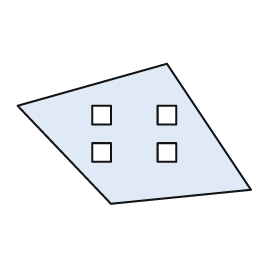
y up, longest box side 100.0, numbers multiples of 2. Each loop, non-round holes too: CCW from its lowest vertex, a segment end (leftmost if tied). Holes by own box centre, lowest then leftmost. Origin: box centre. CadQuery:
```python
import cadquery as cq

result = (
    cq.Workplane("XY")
    .moveTo(-10.0, -30.0)
    .lineTo(50.0, -24.0)
    .lineTo(14.0, 30.0)
    .lineTo(-50.0, 12.0)
    .close()
    .moveTo(-18.0, -12.0)
    .lineTo(-10.0, -12.0)
    .lineTo(-10.0, -4.0)
    .lineTo(-18.0, -4.0)
    .close()
    .moveTo(10.0, -12.0)
    .lineTo(18.0, -12.0)
    .lineTo(18.0, -4.0)
    .lineTo(10.0, -4.0)
    .close()
    .moveTo(-18.0, 4.0)
    .lineTo(-10.0, 4.0)
    .lineTo(-10.0, 12.0)
    .lineTo(-18.0, 12.0)
    .close()
    .moveTo(10.0, 4.0)
    .lineTo(18.0, 4.0)
    .lineTo(18.0, 12.0)
    .lineTo(10.0, 12.0)
    .close()
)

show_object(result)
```